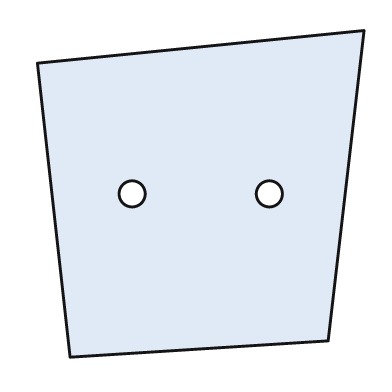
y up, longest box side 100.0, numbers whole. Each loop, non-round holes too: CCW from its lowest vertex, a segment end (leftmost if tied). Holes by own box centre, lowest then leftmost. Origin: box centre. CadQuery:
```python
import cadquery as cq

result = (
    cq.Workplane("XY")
    .moveTo(-40.0, -50.0)
    .lineTo(39.0, -45.0)
    .lineTo(50.0, 50.0)
    .lineTo(-50.0, 40.0)
    .close()
    .moveTo(-21.0, 0.0)
    .circle(4.0)
    .moveTo(21.0, 0.0)
    .circle(4.0)
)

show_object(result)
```